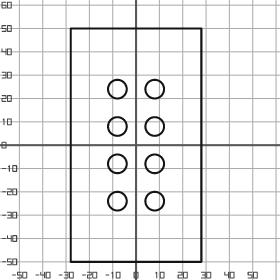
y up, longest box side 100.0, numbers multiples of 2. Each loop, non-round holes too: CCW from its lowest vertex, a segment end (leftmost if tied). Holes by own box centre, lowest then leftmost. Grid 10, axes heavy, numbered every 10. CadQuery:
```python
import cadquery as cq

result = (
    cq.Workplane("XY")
    .moveTo(-28.0, -50.0)
    .lineTo(28.0, -50.0)
    .lineTo(28.0, 50.0)
    .lineTo(-28.0, 50.0)
    .close()
    .moveTo(-8.0, -24.0)
    .circle(4.0)
    .moveTo(8.0, -24.0)
    .circle(4.0)
    .moveTo(-8.0, -8.0)
    .circle(4.0)
    .moveTo(8.0, -8.0)
    .circle(4.0)
    .moveTo(-8.0, 8.0)
    .circle(4.0)
    .moveTo(8.0, 8.0)
    .circle(4.0)
    .moveTo(-8.0, 24.0)
    .circle(4.0)
    .moveTo(8.0, 24.0)
    .circle(4.0)
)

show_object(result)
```